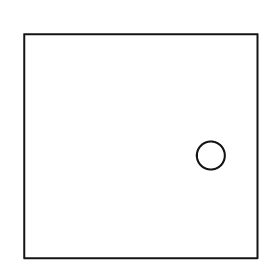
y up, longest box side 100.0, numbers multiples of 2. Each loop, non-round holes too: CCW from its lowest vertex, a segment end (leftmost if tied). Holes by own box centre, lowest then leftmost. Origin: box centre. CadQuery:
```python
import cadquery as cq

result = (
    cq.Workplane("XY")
    .moveTo(-50.0, -48.0)
    .lineTo(50.0, -48.0)
    .lineTo(50.0, 48.0)
    .lineTo(-50.0, 48.0)
    .close()
    .moveTo(30.0, -4.0)
    .circle(6.0)
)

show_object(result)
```